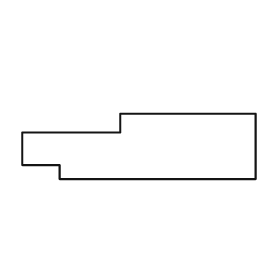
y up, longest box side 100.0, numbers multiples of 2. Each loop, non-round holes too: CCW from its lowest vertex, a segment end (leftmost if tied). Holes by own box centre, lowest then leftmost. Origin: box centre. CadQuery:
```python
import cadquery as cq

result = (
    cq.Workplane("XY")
    .moveTo(-34.0, -14.0)
    .lineTo(50.0, -14.0)
    .lineTo(50.0, 14.0)
    .lineTo(-8.0, 14.0)
    .lineTo(-8.0, 6.0)
    .lineTo(-50.0, 6.0)
    .lineTo(-50.0, -8.0)
    .lineTo(-34.0, -8.0)
    .close()
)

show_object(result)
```